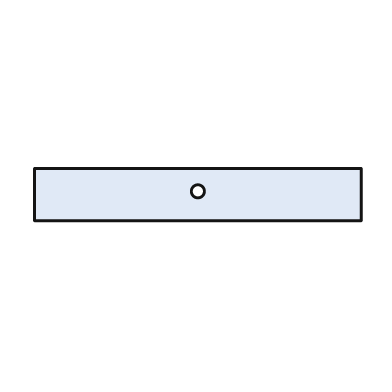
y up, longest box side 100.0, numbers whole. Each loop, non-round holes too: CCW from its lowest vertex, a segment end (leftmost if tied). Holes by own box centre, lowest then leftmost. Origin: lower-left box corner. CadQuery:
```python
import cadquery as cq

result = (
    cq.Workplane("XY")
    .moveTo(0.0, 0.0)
    .lineTo(100.0, 0.0)
    .lineTo(100.0, 16.0)
    .lineTo(0.0, 16.0)
    .close()
    .moveTo(50.0, 9.0)
    .circle(2.0)
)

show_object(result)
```